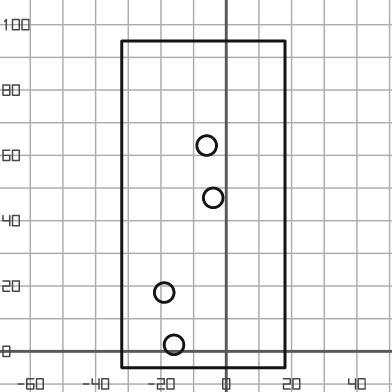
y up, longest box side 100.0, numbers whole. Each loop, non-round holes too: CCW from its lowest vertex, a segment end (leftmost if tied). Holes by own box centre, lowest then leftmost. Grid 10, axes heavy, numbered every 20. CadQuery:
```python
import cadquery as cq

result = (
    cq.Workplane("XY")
    .moveTo(-32.0, -5.0)
    .lineTo(18.0, -5.0)
    .lineTo(18.0, 95.0)
    .lineTo(-32.0, 95.0)
    .close()
    .moveTo(-16.0, 2.0)
    .circle(3.0)
    .moveTo(-19.0, 18.0)
    .circle(3.0)
    .moveTo(-4.0, 47.0)
    .circle(3.0)
    .moveTo(-6.0, 63.0)
    .circle(3.0)
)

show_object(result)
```